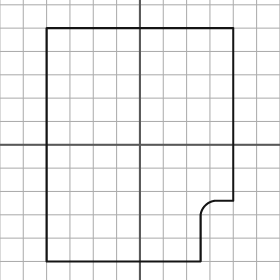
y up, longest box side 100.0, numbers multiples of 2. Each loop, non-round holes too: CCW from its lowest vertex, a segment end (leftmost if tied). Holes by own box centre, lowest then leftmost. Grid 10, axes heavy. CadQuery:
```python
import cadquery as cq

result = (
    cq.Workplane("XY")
    .moveTo(-40.0, -50.0)
    .lineTo(26.0, -50.0)
    .lineTo(26.0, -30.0)
    .threePointArc((28.0, -26.0), (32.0, -24.0))
    .lineTo(40.0, -24.0)
    .lineTo(40.0, 50.0)
    .lineTo(-40.0, 50.0)
    .close()
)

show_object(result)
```